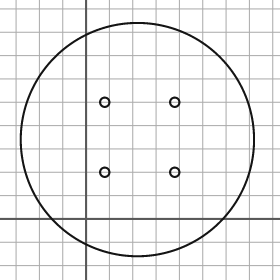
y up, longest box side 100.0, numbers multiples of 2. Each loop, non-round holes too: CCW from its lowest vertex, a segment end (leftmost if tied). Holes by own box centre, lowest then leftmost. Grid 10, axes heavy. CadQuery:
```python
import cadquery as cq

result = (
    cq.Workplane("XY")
    .moveTo(22.0, 34.0)
    .circle(50.0)
    .moveTo(8.0, 20.0)
    .circle(2.0)
    .moveTo(38.0, 20.0)
    .circle(2.0)
    .moveTo(8.0, 50.0)
    .circle(2.0)
    .moveTo(38.0, 50.0)
    .circle(2.0)
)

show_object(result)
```